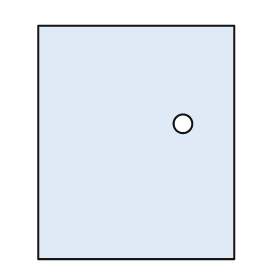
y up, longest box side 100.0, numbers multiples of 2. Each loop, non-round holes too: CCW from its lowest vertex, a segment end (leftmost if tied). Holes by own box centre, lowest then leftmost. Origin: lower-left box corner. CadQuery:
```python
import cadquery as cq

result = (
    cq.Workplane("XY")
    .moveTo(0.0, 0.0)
    .lineTo(84.0, 0.0)
    .lineTo(84.0, 100.0)
    .lineTo(0.0, 100.0)
    .close()
    .moveTo(62.0, 58.0)
    .circle(4.0)
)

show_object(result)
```